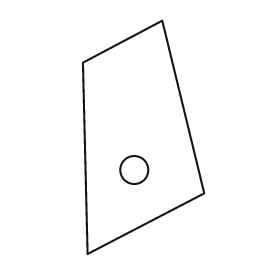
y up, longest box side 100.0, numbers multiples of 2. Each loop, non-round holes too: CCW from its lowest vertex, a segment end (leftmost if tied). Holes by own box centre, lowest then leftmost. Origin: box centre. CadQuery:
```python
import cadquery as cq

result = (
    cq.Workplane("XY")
    .moveTo(-24.0, -50.0)
    .lineTo(26.0, -24.0)
    .lineTo(8.0, 50.0)
    .lineTo(-26.0, 32.0)
    .close()
    .moveTo(-4.0, -14.0)
    .circle(6.0)
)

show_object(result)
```